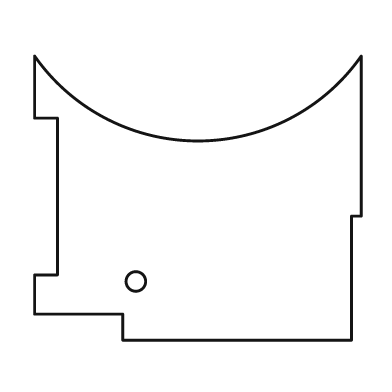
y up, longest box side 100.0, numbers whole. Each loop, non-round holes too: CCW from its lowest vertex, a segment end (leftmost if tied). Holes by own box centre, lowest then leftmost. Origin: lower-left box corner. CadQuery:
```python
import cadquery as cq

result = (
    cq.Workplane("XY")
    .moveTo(27.0, 0.0)
    .lineTo(97.0, 0.0)
    .lineTo(97.0, 38.0)
    .lineTo(100.0, 38.0)
    .lineTo(100.0, 87.0)
    .threePointArc((50.0, 61.0), (0.0, 87.0))
    .lineTo(0.0, 68.0)
    .lineTo(7.0, 68.0)
    .lineTo(7.0, 20.0)
    .lineTo(0.0, 20.0)
    .lineTo(0.0, 8.0)
    .lineTo(27.0, 8.0)
    .close()
    .moveTo(31.0, 18.0)
    .circle(3.0)
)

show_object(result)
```